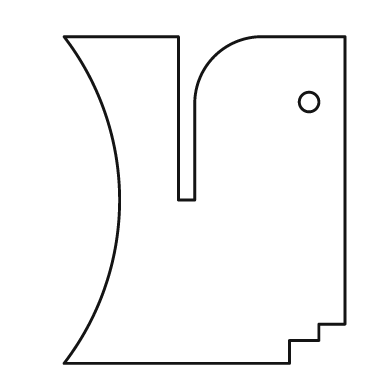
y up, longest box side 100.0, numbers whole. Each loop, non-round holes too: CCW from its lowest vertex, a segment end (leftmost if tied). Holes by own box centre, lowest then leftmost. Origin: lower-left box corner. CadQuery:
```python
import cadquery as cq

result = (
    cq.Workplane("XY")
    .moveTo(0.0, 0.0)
    .lineTo(69.0, 0.0)
    .lineTo(69.0, 7.0)
    .lineTo(78.0, 7.0)
    .lineTo(78.0, 12.0)
    .lineTo(86.0, 12.0)
    .lineTo(86.0, 100.0)
    .lineTo(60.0, 100.0)
    .threePointArc((46.0, 94.0), (40.0, 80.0))
    .lineTo(40.0, 50.0)
    .lineTo(35.0, 50.0)
    .lineTo(35.0, 100.0)
    .lineTo(0.0, 100.0)
    .threePointArc((17.0, 50.0), (0.0, 0.0))
    .close()
    .moveTo(75.0, 80.0)
    .circle(3.0)
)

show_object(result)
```